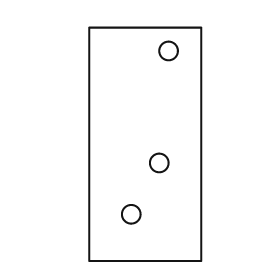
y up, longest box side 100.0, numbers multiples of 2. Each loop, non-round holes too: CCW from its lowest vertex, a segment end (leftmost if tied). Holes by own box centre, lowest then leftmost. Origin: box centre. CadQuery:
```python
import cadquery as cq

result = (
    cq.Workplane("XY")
    .moveTo(-24.0, -50.0)
    .lineTo(24.0, -50.0)
    .lineTo(24.0, 50.0)
    .lineTo(-24.0, 50.0)
    .close()
    .moveTo(-6.0, -30.0)
    .circle(4.0)
    .moveTo(6.0, -8.0)
    .circle(4.0)
    .moveTo(10.0, 40.0)
    .circle(4.0)
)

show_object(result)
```